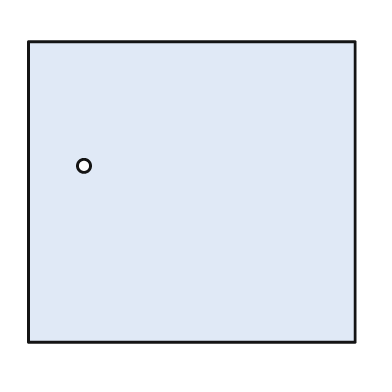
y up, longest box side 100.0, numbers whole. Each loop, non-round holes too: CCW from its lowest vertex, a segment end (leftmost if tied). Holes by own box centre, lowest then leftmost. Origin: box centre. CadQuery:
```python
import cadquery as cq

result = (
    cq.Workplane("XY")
    .moveTo(-50.0, -46.0)
    .lineTo(50.0, -46.0)
    .lineTo(50.0, 46.0)
    .lineTo(-50.0, 46.0)
    .close()
    .moveTo(-33.0, 8.0)
    .circle(2.0)
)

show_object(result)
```